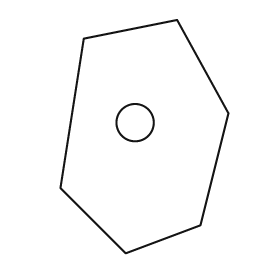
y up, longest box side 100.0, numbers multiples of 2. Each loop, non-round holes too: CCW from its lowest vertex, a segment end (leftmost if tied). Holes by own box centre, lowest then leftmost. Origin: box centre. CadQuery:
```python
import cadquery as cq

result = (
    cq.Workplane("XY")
    .moveTo(-8.0, -50.0)
    .lineTo(24.0, -38.0)
    .lineTo(36.0, 10.0)
    .lineTo(14.0, 50.0)
    .lineTo(-26.0, 42.0)
    .lineTo(-36.0, -22.0)
    .close()
    .moveTo(-4.0, 6.0)
    .circle(8.0)
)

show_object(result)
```